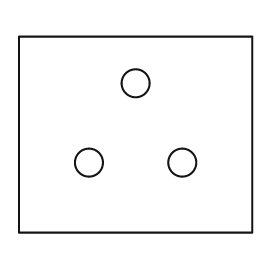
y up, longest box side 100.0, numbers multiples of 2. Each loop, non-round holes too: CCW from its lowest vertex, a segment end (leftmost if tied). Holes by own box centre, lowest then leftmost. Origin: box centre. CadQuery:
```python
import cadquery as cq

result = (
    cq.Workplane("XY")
    .moveTo(-50.0, -42.0)
    .lineTo(50.0, -42.0)
    .lineTo(50.0, 42.0)
    .lineTo(-50.0, 42.0)
    .close()
    .moveTo(-20.0, -12.0)
    .circle(6.0)
    .moveTo(20.0, -12.0)
    .circle(6.0)
    .moveTo(0.0, 22.0)
    .circle(6.0)
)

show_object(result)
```